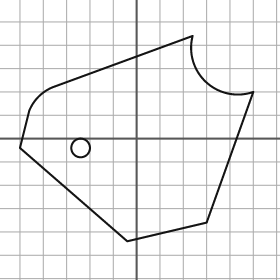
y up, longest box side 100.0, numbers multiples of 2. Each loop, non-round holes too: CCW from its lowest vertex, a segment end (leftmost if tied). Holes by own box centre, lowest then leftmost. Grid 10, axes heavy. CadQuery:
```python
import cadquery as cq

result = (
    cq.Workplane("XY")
    .moveTo(-4.0, -44.0)
    .lineTo(30.0, -36.0)
    .lineTo(50.0, 20.0)
    .threePointArc((30.0, 24.0), (24.0, 44.0))
    .lineTo(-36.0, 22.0)
    .threePointArc((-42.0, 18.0), (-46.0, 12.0))
    .lineTo(-50.0, -4.0)
    .close()
    .moveTo(-24.0, -4.0)
    .circle(4.0)
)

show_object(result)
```